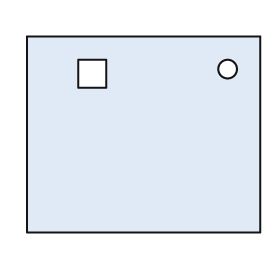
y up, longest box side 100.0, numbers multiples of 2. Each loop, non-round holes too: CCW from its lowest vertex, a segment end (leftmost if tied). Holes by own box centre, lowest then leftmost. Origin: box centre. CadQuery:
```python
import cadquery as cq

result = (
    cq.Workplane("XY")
    .moveTo(-50.0, -42.0)
    .lineTo(50.0, -42.0)
    .lineTo(50.0, 42.0)
    .lineTo(-50.0, 42.0)
    .close()
    .moveTo(-28.0, 20.0)
    .lineTo(-16.0, 20.0)
    .lineTo(-16.0, 32.0)
    .lineTo(-28.0, 32.0)
    .close()
    .moveTo(36.0, 28.0)
    .circle(4.0)
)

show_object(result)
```